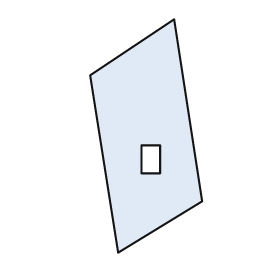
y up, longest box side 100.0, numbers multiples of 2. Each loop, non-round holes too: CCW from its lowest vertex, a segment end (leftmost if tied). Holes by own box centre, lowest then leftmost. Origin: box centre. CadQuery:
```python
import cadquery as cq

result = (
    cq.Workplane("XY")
    .moveTo(-12.0, -50.0)
    .lineTo(24.0, -28.0)
    .lineTo(12.0, 50.0)
    .lineTo(-24.0, 26.0)
    .close()
    .moveTo(-2.0, -16.0)
    .lineTo(6.0, -16.0)
    .lineTo(6.0, -4.0)
    .lineTo(-2.0, -4.0)
    .close()
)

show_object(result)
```